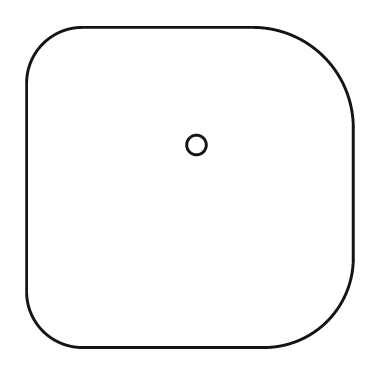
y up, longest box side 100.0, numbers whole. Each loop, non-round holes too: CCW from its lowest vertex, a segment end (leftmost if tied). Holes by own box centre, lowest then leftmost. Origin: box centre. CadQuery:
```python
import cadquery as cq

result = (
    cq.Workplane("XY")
    .moveTo(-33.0, -49.0)
    .lineTo(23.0, -49.0)
    .threePointArc((42.0, -41.0), (50.0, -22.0))
    .lineTo(50.0, 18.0)
    .threePointArc((41.0, 40.0), (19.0, 49.0))
    .lineTo(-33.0, 49.0)
    .threePointArc((-45.0, 44.0), (-50.0, 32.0))
    .lineTo(-50.0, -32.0)
    .threePointArc((-45.0, -44.0), (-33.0, -49.0))
    .close()
    .moveTo(2.0, 13.0)
    .circle(3.0)
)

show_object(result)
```